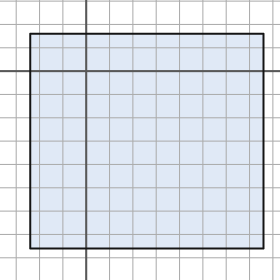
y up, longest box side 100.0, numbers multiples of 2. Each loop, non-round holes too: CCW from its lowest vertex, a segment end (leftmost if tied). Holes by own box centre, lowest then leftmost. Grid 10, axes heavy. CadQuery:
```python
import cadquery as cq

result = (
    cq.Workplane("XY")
    .moveTo(-24.0, -76.0)
    .lineTo(76.0, -76.0)
    .lineTo(76.0, 16.0)
    .lineTo(-24.0, 16.0)
    .close()
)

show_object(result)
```